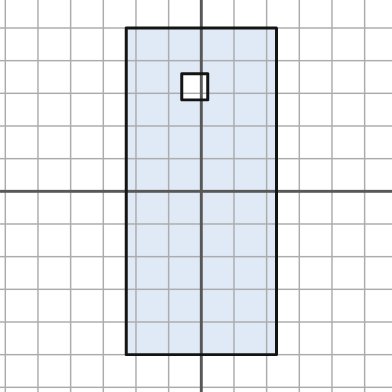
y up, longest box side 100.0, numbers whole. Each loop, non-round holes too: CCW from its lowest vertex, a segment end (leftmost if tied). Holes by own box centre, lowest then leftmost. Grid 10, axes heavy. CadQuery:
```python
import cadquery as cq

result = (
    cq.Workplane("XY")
    .moveTo(-23.0, -50.0)
    .lineTo(23.0, -50.0)
    .lineTo(23.0, 50.0)
    .lineTo(-23.0, 50.0)
    .close()
    .moveTo(-6.0, 28.0)
    .lineTo(2.0, 28.0)
    .lineTo(2.0, 36.0)
    .lineTo(-6.0, 36.0)
    .close()
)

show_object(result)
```